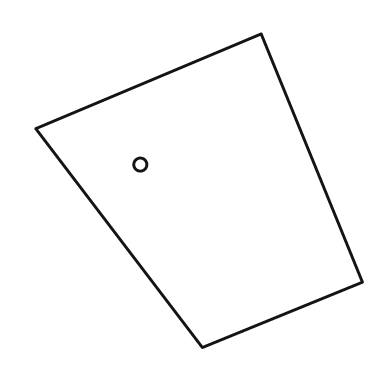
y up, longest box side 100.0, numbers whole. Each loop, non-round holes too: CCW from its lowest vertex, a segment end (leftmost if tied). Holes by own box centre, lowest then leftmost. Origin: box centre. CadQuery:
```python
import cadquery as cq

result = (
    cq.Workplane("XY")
    .moveTo(1.0, -48.0)
    .lineTo(50.0, -28.0)
    .lineTo(19.0, 48.0)
    .lineTo(-50.0, 19.0)
    .close()
    .moveTo(-18.0, 8.0)
    .circle(2.0)
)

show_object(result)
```